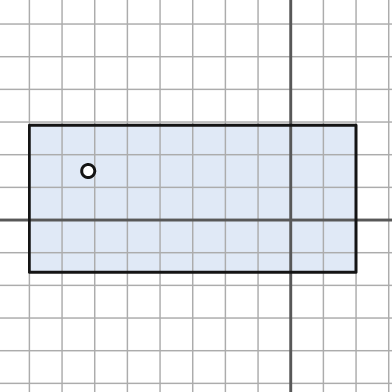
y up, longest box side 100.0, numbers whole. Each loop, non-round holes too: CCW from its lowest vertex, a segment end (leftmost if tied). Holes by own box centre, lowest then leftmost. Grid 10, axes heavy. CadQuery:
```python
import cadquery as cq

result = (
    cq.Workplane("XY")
    .moveTo(-80.0, -16.0)
    .lineTo(20.0, -16.0)
    .lineTo(20.0, 29.0)
    .lineTo(-80.0, 29.0)
    .close()
    .moveTo(-62.0, 15.0)
    .circle(2.0)
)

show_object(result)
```